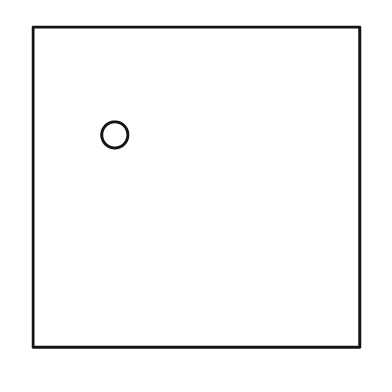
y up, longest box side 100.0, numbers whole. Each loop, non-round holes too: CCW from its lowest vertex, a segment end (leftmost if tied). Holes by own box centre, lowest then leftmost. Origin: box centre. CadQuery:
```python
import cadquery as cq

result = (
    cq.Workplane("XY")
    .moveTo(-50.0, -49.0)
    .lineTo(50.0, -49.0)
    .lineTo(50.0, 49.0)
    .lineTo(-50.0, 49.0)
    .close()
    .moveTo(-25.0, 16.0)
    .circle(4.0)
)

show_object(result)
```